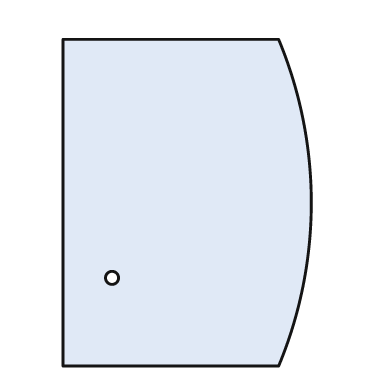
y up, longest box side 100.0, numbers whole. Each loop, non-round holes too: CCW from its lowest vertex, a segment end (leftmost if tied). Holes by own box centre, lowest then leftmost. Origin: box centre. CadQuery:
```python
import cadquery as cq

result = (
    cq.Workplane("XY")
    .moveTo(-38.0, -50.0)
    .lineTo(28.0, -50.0)
    .threePointArc((38.0, 0.0), (28.0, 50.0))
    .lineTo(-38.0, 50.0)
    .close()
    .moveTo(-23.0, -23.0)
    .circle(2.0)
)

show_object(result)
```